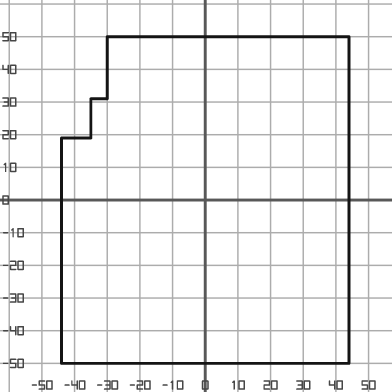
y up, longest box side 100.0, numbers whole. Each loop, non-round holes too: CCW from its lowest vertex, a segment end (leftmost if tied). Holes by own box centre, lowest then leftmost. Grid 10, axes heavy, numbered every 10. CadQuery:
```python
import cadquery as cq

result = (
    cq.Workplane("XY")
    .moveTo(-44.0, -50.0)
    .lineTo(44.0, -50.0)
    .lineTo(44.0, 50.0)
    .lineTo(-30.0, 50.0)
    .lineTo(-30.0, 31.0)
    .lineTo(-35.0, 31.0)
    .lineTo(-35.0, 19.0)
    .lineTo(-44.0, 19.0)
    .close()
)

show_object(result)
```